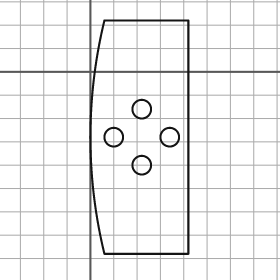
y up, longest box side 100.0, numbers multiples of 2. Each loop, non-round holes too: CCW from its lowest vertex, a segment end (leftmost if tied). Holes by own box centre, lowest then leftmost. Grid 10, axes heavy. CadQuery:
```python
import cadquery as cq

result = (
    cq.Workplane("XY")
    .moveTo(6.0, -78.0)
    .lineTo(42.0, -78.0)
    .lineTo(42.0, 22.0)
    .lineTo(6.0, 22.0)
    .threePointArc((0.0, -28.0), (6.0, -78.0))
    .close()
    .moveTo(22.0, -40.0)
    .circle(4.0)
    .moveTo(10.0, -28.0)
    .circle(4.0)
    .moveTo(34.0, -28.0)
    .circle(4.0)
    .moveTo(22.0, -16.0)
    .circle(4.0)
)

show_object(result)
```